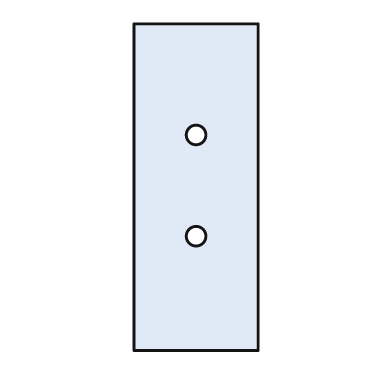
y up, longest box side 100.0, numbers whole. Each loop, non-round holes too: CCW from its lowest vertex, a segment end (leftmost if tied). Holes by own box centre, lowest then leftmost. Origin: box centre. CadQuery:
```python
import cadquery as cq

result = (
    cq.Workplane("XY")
    .moveTo(-19.0, -50.0)
    .lineTo(19.0, -50.0)
    .lineTo(19.0, 50.0)
    .lineTo(-19.0, 50.0)
    .close()
    .moveTo(0.0, -15.0)
    .circle(3.0)
    .moveTo(0.0, 16.0)
    .circle(3.0)
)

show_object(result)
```